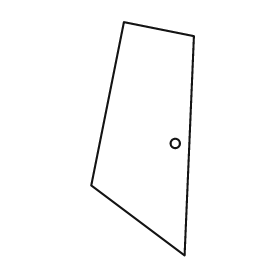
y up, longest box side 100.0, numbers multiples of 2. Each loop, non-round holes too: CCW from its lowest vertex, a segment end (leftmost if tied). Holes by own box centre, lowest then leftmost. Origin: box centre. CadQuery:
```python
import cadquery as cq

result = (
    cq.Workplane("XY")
    .moveTo(18.0, -50.0)
    .lineTo(22.0, 44.0)
    .lineTo(-8.0, 50.0)
    .lineTo(-22.0, -20.0)
    .close()
    .moveTo(14.0, -2.0)
    .circle(2.0)
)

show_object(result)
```